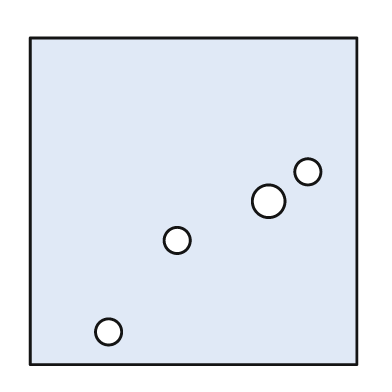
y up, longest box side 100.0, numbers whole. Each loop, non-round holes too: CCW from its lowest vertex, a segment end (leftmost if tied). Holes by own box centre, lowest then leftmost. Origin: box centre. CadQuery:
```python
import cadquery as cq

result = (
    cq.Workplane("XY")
    .moveTo(-50.0, -50.0)
    .lineTo(50.0, -50.0)
    .lineTo(50.0, 50.0)
    .lineTo(-50.0, 50.0)
    .close()
    .moveTo(-26.0, -40.0)
    .circle(4.0)
    .moveTo(-5.0, -12.0)
    .circle(4.0)
    .moveTo(23.0, 0.0)
    .circle(5.0)
    .moveTo(35.0, 9.0)
    .circle(4.0)
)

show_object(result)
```